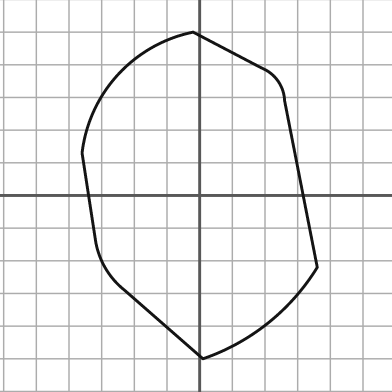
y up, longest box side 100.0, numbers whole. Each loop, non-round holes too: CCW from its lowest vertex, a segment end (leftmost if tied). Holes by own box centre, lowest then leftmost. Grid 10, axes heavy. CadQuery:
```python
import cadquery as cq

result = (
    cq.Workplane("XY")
    .moveTo(1.0, -50.0)
    .threePointArc((21.0, -39.0), (36.0, -22.0))
    .lineTo(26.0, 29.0)
    .threePointArc((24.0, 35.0), (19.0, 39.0))
    .lineTo(-2.0, 50.0)
    .threePointArc((-25.0, 37.0), (-36.0, 13.0))
    .lineTo(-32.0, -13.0)
    .threePointArc((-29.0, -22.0), (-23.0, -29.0))
    .close()
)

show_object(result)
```